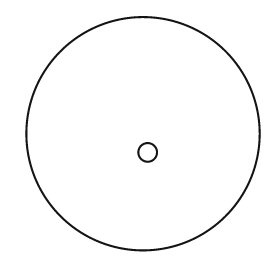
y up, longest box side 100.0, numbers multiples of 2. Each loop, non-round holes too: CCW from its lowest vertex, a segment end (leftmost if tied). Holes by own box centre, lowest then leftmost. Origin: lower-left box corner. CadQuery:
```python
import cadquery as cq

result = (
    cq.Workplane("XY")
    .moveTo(50.0, 50.0)
    .circle(50.0)
    .moveTo(52.0, 42.0)
    .circle(4.0)
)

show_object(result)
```